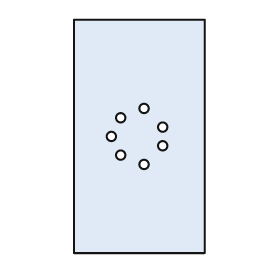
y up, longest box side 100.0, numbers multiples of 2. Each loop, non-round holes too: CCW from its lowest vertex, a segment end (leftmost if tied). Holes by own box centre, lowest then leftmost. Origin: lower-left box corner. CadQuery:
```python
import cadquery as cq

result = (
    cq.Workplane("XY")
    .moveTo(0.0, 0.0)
    .lineTo(56.0, 0.0)
    .lineTo(56.0, 100.0)
    .lineTo(0.0, 100.0)
    .close()
    .moveTo(30.0, 38.0)
    .circle(2.0)
    .moveTo(20.0, 42.0)
    .circle(2.0)
    .moveTo(38.0, 46.0)
    .circle(2.0)
    .moveTo(16.0, 50.0)
    .circle(2.0)
    .moveTo(38.0, 54.0)
    .circle(2.0)
    .moveTo(20.0, 58.0)
    .circle(2.0)
    .moveTo(30.0, 62.0)
    .circle(2.0)
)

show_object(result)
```